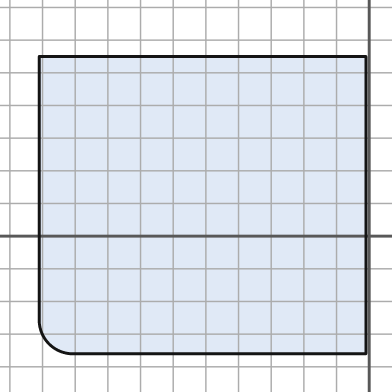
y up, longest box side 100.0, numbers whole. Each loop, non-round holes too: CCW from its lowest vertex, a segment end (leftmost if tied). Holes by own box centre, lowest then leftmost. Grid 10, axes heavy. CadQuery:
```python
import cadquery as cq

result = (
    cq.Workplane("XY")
    .moveTo(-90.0, -36.0)
    .lineTo(-1.0, -36.0)
    .lineTo(-1.0, 55.0)
    .lineTo(-101.0, 55.0)
    .lineTo(-101.0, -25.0)
    .threePointArc((-98.0, -33.0), (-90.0, -36.0))
    .close()
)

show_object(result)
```